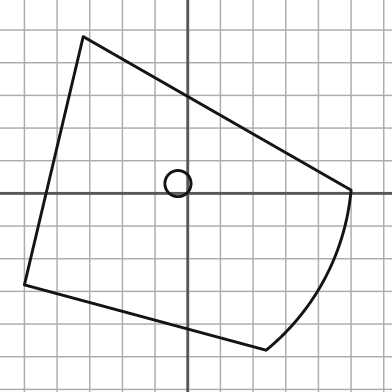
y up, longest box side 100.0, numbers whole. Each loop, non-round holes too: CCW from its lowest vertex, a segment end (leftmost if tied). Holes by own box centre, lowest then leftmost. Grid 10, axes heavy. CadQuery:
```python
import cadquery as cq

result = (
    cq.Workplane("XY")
    .moveTo(24.0, -48.0)
    .threePointArc((42.0, -26.0), (50.0, 1.0))
    .lineTo(-32.0, 48.0)
    .lineTo(-50.0, -28.0)
    .close()
    .moveTo(-3.0, 3.0)
    .circle(4.0)
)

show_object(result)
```